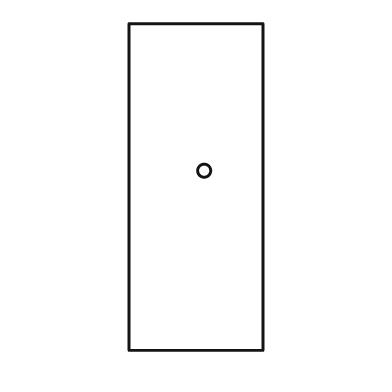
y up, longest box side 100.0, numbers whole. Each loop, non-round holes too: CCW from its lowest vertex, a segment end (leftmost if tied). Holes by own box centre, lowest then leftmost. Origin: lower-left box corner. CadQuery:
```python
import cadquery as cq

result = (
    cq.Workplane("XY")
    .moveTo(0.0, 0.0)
    .lineTo(41.0, 0.0)
    .lineTo(41.0, 100.0)
    .lineTo(0.0, 100.0)
    .close()
    .moveTo(23.0, 55.0)
    .circle(2.0)
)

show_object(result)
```